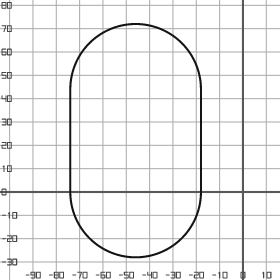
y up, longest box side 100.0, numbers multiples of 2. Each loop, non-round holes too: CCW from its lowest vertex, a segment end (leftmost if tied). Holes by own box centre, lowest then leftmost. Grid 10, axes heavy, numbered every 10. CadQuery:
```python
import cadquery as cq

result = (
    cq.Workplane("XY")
    .moveTo(-74.0, 0.0)
    .threePointArc((-46.0, -28.0), (-18.0, 0.0))
    .lineTo(-18.0, 44.0)
    .threePointArc((-46.0, 72.0), (-74.0, 44.0))
    .close()
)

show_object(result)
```